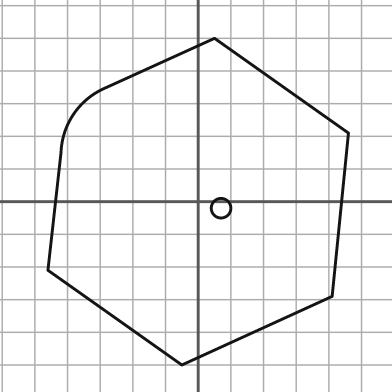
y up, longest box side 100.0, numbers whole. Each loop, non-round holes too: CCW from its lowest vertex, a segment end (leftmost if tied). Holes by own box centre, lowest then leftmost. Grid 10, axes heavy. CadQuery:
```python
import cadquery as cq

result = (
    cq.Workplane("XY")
    .moveTo(-5.0, -50.0)
    .lineTo(41.0, -29.0)
    .lineTo(46.0, 21.0)
    .lineTo(5.0, 50.0)
    .lineTo(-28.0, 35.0)
    .threePointArc((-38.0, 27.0), (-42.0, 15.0))
    .lineTo(-46.0, -21.0)
    .close()
    .moveTo(7.0, -2.0)
    .circle(3.0)
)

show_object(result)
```